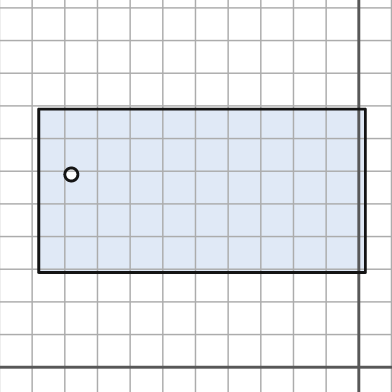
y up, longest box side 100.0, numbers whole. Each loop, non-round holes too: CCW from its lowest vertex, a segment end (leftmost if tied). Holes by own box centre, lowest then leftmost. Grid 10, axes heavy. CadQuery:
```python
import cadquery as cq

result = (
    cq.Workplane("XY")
    .moveTo(-98.0, 29.0)
    .lineTo(2.0, 29.0)
    .lineTo(2.0, 79.0)
    .lineTo(-98.0, 79.0)
    .close()
    .moveTo(-88.0, 59.0)
    .circle(2.0)
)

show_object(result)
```